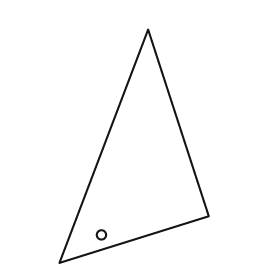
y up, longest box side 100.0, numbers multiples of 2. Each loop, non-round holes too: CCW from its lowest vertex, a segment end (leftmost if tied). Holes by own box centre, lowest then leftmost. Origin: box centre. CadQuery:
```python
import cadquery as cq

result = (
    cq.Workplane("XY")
    .moveTo(-32.0, -50.0)
    .lineTo(32.0, -30.0)
    .lineTo(6.0, 50.0)
    .close()
    .moveTo(-14.0, -38.0)
    .circle(2.0)
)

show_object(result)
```